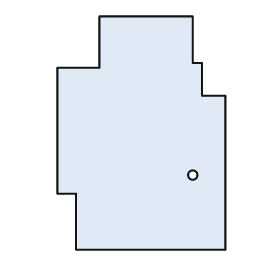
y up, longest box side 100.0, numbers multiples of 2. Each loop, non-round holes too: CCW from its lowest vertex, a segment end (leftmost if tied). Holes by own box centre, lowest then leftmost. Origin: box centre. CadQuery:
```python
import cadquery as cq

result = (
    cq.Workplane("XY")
    .moveTo(-28.0, -50.0)
    .lineTo(36.0, -50.0)
    .lineTo(36.0, 16.0)
    .lineTo(26.0, 16.0)
    .lineTo(26.0, 30.0)
    .lineTo(22.0, 30.0)
    .lineTo(22.0, 50.0)
    .lineTo(-18.0, 50.0)
    .lineTo(-18.0, 28.0)
    .lineTo(-36.0, 28.0)
    .lineTo(-36.0, -26.0)
    .lineTo(-28.0, -26.0)
    .close()
    .moveTo(22.0, -18.0)
    .circle(2.0)
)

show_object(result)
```